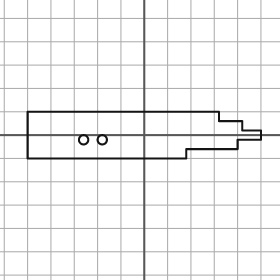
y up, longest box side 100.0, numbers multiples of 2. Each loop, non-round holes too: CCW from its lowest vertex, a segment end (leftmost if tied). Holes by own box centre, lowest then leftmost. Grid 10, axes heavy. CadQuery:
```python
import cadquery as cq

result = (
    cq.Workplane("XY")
    .moveTo(-50.0, -10.0)
    .lineTo(18.0, -10.0)
    .lineTo(18.0, -6.0)
    .lineTo(40.0, -6.0)
    .lineTo(40.0, -2.0)
    .lineTo(50.0, -2.0)
    .lineTo(50.0, 2.0)
    .lineTo(42.0, 2.0)
    .lineTo(42.0, 6.0)
    .lineTo(32.0, 6.0)
    .lineTo(32.0, 10.0)
    .lineTo(-50.0, 10.0)
    .close()
    .moveTo(-26.0, -2.0)
    .circle(2.0)
    .moveTo(-18.0, -2.0)
    .circle(2.0)
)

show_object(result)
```